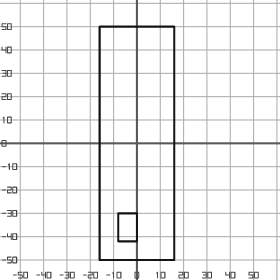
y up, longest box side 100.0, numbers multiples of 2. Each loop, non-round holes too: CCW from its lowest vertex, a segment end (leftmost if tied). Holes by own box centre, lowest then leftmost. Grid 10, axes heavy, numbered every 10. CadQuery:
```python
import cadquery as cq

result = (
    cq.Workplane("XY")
    .moveTo(-16.0, -50.0)
    .lineTo(16.0, -50.0)
    .lineTo(16.0, 50.0)
    .lineTo(-16.0, 50.0)
    .close()
    .moveTo(-8.0, -42.0)
    .lineTo(0.0, -42.0)
    .lineTo(0.0, -30.0)
    .lineTo(-8.0, -30.0)
    .close()
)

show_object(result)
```